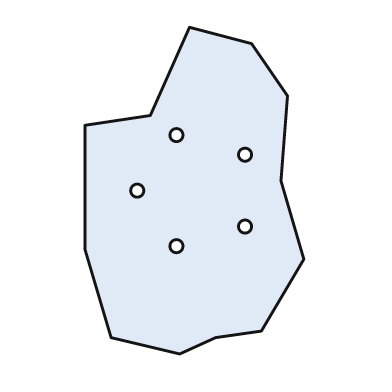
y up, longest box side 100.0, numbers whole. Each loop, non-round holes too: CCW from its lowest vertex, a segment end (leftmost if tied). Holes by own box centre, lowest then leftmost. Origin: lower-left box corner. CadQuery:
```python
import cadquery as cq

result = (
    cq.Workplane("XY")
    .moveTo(29.0, 0.0)
    .lineTo(40.0, 5.0)
    .lineTo(54.0, 7.0)
    .lineTo(67.0, 29.0)
    .lineTo(60.0, 53.0)
    .lineTo(62.0, 79.0)
    .lineTo(51.0, 95.0)
    .lineTo(32.0, 100.0)
    .lineTo(20.0, 73.0)
    .lineTo(0.0, 70.0)
    .lineTo(0.0, 32.0)
    .lineTo(8.0, 5.0)
    .close()
    .moveTo(28.0, 33.0)
    .circle(2.0)
    .moveTo(49.0, 39.0)
    .circle(2.0)
    .moveTo(16.0, 50.0)
    .circle(2.0)
    .moveTo(49.0, 61.0)
    .circle(2.0)
    .moveTo(28.0, 67.0)
    .circle(2.0)
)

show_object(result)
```